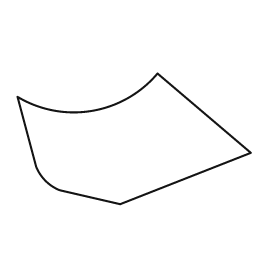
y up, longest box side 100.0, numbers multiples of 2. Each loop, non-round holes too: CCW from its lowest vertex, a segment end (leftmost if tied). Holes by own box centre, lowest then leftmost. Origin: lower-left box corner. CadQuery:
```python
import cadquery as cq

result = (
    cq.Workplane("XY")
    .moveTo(44.0, 0.0)
    .lineTo(100.0, 22.0)
    .lineTo(60.0, 56.0)
    .threePointArc((32.0, 40.0), (0.0, 46.0))
    .lineTo(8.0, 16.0)
    .threePointArc((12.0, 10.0), (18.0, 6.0))
    .close()
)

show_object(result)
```